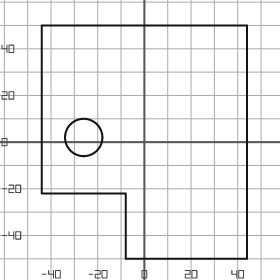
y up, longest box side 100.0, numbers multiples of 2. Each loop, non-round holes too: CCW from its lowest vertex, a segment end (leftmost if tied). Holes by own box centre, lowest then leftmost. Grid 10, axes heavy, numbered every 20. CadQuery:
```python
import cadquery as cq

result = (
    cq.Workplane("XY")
    .moveTo(-8.0, -50.0)
    .lineTo(44.0, -50.0)
    .lineTo(44.0, 50.0)
    .lineTo(-44.0, 50.0)
    .lineTo(-44.0, -22.0)
    .lineTo(-8.0, -22.0)
    .close()
    .moveTo(-26.0, 2.0)
    .circle(8.0)
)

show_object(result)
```